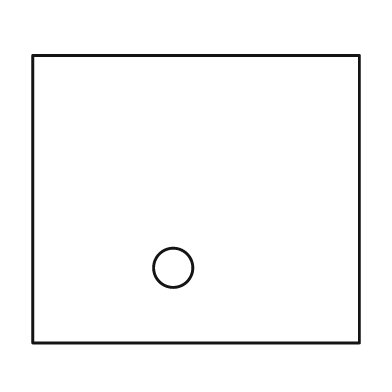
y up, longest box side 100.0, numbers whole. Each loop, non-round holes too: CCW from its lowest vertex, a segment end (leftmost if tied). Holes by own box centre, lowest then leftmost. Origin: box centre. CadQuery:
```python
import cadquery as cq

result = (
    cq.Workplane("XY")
    .moveTo(-50.0, -44.0)
    .lineTo(50.0, -44.0)
    .lineTo(50.0, 44.0)
    .lineTo(-50.0, 44.0)
    .close()
    .moveTo(-7.0, -21.0)
    .circle(6.0)
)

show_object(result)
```